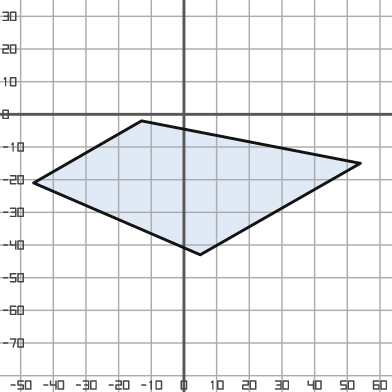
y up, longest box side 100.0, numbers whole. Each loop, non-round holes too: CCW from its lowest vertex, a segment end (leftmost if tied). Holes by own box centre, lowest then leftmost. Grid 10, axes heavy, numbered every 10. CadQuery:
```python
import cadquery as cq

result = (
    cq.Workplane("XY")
    .moveTo(5.0, -43.0)
    .lineTo(54.0, -15.0)
    .lineTo(-13.0, -2.0)
    .lineTo(-46.0, -21.0)
    .close()
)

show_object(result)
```